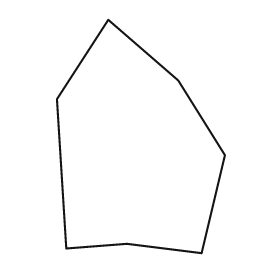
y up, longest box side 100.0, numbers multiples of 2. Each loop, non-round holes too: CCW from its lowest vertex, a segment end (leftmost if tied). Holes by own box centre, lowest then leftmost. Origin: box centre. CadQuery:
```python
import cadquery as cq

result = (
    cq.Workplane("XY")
    .moveTo(26.0, -50.0)
    .lineTo(36.0, -8.0)
    .lineTo(16.0, 24.0)
    .lineTo(-14.0, 50.0)
    .lineTo(-36.0, 16.0)
    .lineTo(-32.0, -48.0)
    .lineTo(-6.0, -46.0)
    .close()
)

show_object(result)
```